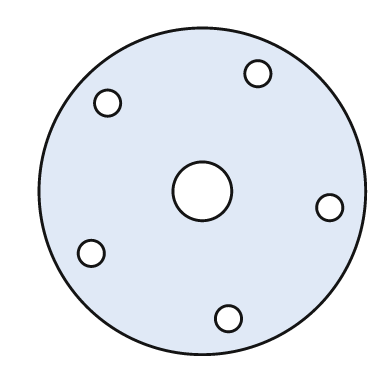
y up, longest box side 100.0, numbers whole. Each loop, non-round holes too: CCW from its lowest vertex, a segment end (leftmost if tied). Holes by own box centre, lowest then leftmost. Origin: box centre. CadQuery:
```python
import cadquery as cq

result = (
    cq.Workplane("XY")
    .moveTo(0.0, 0.0)
    .circle(50.0)
    .moveTo(8.0, -39.0)
    .circle(4.0)
    .moveTo(-34.0, -19.0)
    .circle(4.0)
    .moveTo(39.0, -5.0)
    .circle(4.0)
    .moveTo(0.0, 0.0)
    .circle(9.0)
    .moveTo(-29.0, 27.0)
    .circle(4.0)
    .moveTo(17.0, 36.0)
    .circle(4.0)
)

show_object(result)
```